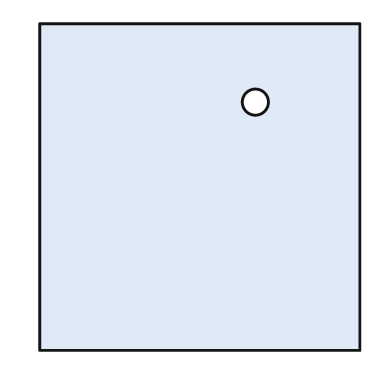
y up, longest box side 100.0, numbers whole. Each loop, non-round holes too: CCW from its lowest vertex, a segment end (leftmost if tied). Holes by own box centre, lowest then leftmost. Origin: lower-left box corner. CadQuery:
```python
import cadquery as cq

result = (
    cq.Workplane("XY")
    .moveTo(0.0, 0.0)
    .lineTo(98.0, 0.0)
    .lineTo(98.0, 100.0)
    .lineTo(0.0, 100.0)
    .close()
    .moveTo(66.0, 76.0)
    .circle(4.0)
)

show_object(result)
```